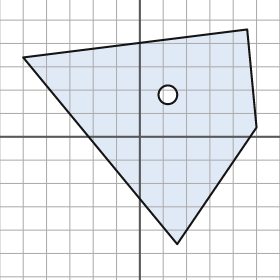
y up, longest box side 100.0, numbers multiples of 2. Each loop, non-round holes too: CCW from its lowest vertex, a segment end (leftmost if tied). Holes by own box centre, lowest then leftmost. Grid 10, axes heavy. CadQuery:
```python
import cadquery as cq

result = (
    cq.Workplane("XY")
    .moveTo(16.0, -46.0)
    .lineTo(50.0, 4.0)
    .lineTo(46.0, 46.0)
    .lineTo(-50.0, 34.0)
    .close()
    .moveTo(12.0, 18.0)
    .circle(4.0)
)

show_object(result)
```